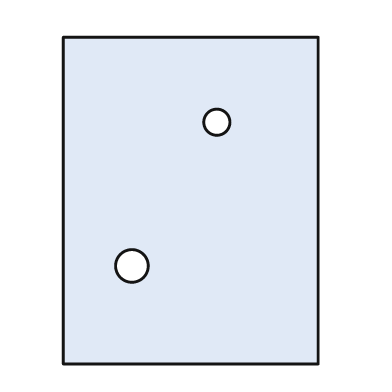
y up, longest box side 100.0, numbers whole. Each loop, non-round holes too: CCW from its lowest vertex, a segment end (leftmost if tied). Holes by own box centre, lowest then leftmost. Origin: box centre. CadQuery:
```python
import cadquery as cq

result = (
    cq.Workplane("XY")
    .moveTo(-39.0, -50.0)
    .lineTo(39.0, -50.0)
    .lineTo(39.0, 50.0)
    .lineTo(-39.0, 50.0)
    .close()
    .moveTo(-18.0, -20.0)
    .circle(5.0)
    .moveTo(8.0, 24.0)
    .circle(4.0)
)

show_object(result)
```